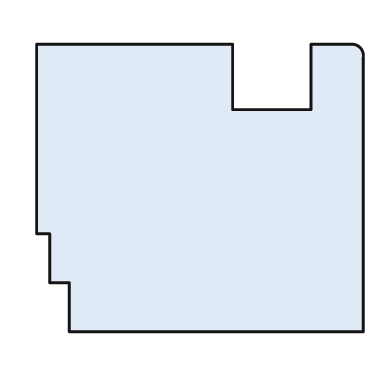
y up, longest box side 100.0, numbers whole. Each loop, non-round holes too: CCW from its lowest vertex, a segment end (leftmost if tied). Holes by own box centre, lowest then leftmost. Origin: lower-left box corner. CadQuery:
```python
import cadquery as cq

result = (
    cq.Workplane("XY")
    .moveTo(10.0, 0.0)
    .lineTo(100.0, 0.0)
    .lineTo(100.0, 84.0)
    .threePointArc((99.0, 87.0), (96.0, 88.0))
    .lineTo(84.0, 88.0)
    .lineTo(84.0, 68.0)
    .lineTo(60.0, 68.0)
    .lineTo(60.0, 88.0)
    .lineTo(0.0, 88.0)
    .lineTo(0.0, 30.0)
    .lineTo(4.0, 30.0)
    .lineTo(4.0, 15.0)
    .lineTo(10.0, 15.0)
    .close()
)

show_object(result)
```